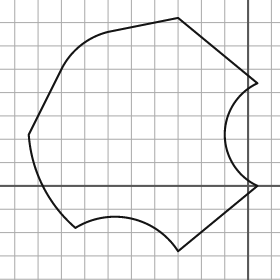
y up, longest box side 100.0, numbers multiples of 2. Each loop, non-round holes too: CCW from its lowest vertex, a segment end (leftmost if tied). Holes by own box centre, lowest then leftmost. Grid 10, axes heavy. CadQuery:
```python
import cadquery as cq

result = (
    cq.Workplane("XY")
    .moveTo(-30.0, -28.0)
    .lineTo(4.0, 0.0)
    .threePointArc((-10.0, 22.0), (4.0, 44.0))
    .lineTo(-30.0, 72.0)
    .lineTo(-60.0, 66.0)
    .threePointArc((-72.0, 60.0), (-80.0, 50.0))
    .lineTo(-94.0, 22.0)
    .threePointArc((-88.0, 0.0), (-74.0, -18.0))
    .threePointArc((-50.0, -14.0), (-30.0, -28.0))
    .close()
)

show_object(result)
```